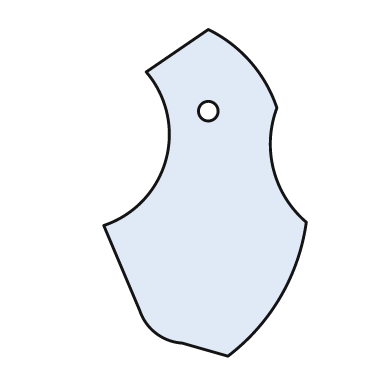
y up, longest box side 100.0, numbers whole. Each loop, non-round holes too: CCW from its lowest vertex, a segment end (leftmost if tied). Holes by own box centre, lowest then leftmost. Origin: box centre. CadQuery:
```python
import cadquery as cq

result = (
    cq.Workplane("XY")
    .moveTo(7.0, -50.0)
    .threePointArc((23.0, -32.0), (31.0, -9.0))
    .threePointArc((21.0, 7.0), (22.0, 26.0))
    .threePointArc((14.0, 40.0), (1.0, 50.0))
    .lineTo(-18.0, 37.0)
    .threePointArc((-12.0, 10.0), (-31.0, -10.0))
    .lineTo(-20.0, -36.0)
    .threePointArc((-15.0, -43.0), (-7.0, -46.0))
    .close()
    .moveTo(1.0, 25.0)
    .circle(3.0)
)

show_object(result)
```